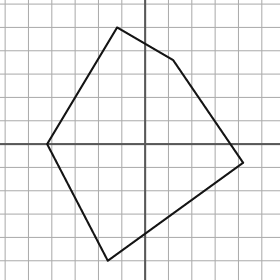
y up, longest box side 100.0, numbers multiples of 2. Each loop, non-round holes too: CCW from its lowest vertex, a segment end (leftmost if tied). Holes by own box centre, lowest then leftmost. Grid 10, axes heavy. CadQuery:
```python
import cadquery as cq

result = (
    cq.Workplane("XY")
    .moveTo(-16.0, -50.0)
    .lineTo(42.0, -8.0)
    .lineTo(12.0, 36.0)
    .lineTo(-12.0, 50.0)
    .lineTo(-42.0, 0.0)
    .close()
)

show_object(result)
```